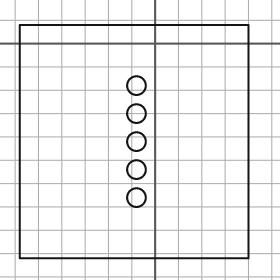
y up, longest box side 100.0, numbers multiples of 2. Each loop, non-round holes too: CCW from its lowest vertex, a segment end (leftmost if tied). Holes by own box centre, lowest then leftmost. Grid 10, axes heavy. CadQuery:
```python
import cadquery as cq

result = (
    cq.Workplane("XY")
    .moveTo(-58.0, -92.0)
    .lineTo(40.0, -92.0)
    .lineTo(40.0, 8.0)
    .lineTo(-58.0, 8.0)
    .close()
    .moveTo(-8.0, -66.0)
    .circle(4.0)
    .moveTo(-8.0, -54.0)
    .circle(4.0)
    .moveTo(-8.0, -42.0)
    .circle(4.0)
    .moveTo(-8.0, -30.0)
    .circle(4.0)
    .moveTo(-8.0, -18.0)
    .circle(4.0)
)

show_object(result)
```